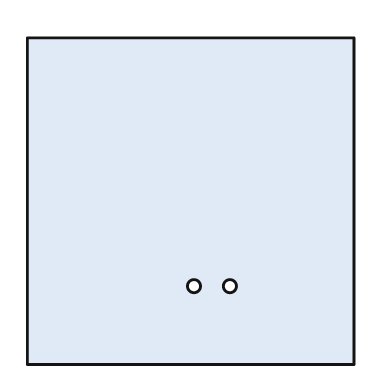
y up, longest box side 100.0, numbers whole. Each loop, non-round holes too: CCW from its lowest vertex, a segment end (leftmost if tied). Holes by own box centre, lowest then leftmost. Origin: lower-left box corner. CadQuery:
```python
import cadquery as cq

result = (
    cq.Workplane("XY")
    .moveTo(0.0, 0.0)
    .lineTo(100.0, 0.0)
    .lineTo(100.0, 100.0)
    .lineTo(0.0, 100.0)
    .close()
    .moveTo(51.0, 24.0)
    .circle(2.0)
    .moveTo(62.0, 24.0)
    .circle(2.0)
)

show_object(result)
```